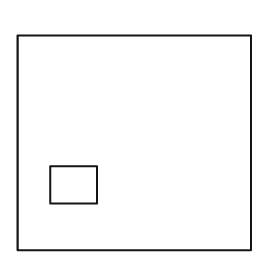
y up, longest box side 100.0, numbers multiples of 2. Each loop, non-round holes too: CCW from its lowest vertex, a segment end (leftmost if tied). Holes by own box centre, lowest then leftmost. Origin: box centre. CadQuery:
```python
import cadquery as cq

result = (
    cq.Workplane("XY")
    .moveTo(-50.0, -46.0)
    .lineTo(50.0, -46.0)
    .lineTo(50.0, 46.0)
    .lineTo(-50.0, 46.0)
    .close()
    .moveTo(-36.0, -26.0)
    .lineTo(-16.0, -26.0)
    .lineTo(-16.0, -10.0)
    .lineTo(-36.0, -10.0)
    .close()
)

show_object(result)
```